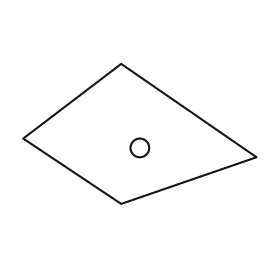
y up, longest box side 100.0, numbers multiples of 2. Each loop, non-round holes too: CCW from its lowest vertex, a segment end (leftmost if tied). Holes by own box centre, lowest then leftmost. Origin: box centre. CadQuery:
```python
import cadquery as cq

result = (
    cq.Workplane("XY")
    .moveTo(-8.0, -30.0)
    .lineTo(50.0, -10.0)
    .lineTo(-8.0, 30.0)
    .lineTo(-50.0, -2.0)
    .close()
    .moveTo(0.0, -6.0)
    .circle(4.0)
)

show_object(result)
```